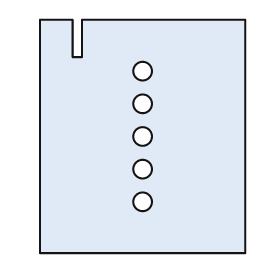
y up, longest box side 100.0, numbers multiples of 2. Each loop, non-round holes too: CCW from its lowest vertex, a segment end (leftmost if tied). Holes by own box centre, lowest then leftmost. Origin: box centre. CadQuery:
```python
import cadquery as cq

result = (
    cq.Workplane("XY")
    .moveTo(-44.0, -50.0)
    .lineTo(44.0, -50.0)
    .lineTo(44.0, 50.0)
    .lineTo(-26.0, 50.0)
    .lineTo(-26.0, 34.0)
    .lineTo(-30.0, 34.0)
    .lineTo(-30.0, 50.0)
    .lineTo(-44.0, 50.0)
    .close()
    .moveTo(0.0, -28.0)
    .circle(4.0)
    .moveTo(0.0, -14.0)
    .circle(4.0)
    .moveTo(0.0, 0.0)
    .circle(4.0)
    .moveTo(0.0, 14.0)
    .circle(4.0)
    .moveTo(0.0, 28.0)
    .circle(4.0)
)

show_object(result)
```